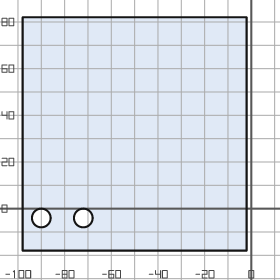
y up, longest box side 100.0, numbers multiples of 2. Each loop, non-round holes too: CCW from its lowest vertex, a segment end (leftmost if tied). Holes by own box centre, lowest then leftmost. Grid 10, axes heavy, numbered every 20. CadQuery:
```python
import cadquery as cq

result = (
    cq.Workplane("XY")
    .moveTo(-98.0, -18.0)
    .lineTo(-2.0, -18.0)
    .lineTo(-2.0, 82.0)
    .lineTo(-98.0, 82.0)
    .close()
    .moveTo(-90.0, -4.0)
    .circle(4.0)
    .moveTo(-72.0, -4.0)
    .circle(4.0)
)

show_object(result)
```